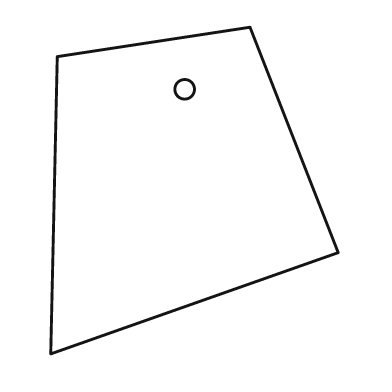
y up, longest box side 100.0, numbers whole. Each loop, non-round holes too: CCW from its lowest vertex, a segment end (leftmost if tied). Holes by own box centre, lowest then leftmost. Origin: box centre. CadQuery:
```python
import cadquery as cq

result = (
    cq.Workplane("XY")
    .moveTo(-44.0, -50.0)
    .lineTo(44.0, -19.0)
    .lineTo(17.0, 50.0)
    .lineTo(-42.0, 41.0)
    .close()
    .moveTo(-3.0, 31.0)
    .circle(3.0)
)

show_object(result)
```